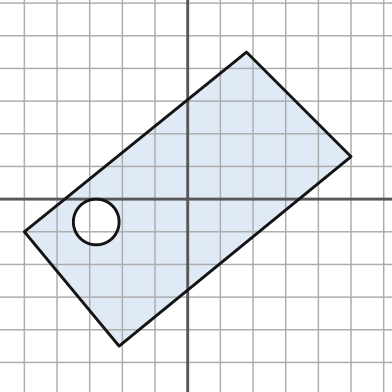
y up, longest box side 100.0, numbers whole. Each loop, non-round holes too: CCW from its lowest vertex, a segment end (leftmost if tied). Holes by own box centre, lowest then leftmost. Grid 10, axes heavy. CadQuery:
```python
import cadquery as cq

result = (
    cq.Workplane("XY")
    .moveTo(-21.0, -45.0)
    .lineTo(50.0, 13.0)
    .lineTo(18.0, 45.0)
    .lineTo(-50.0, -10.0)
    .close()
    .moveTo(-28.0, -7.0)
    .circle(7.0)
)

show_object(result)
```